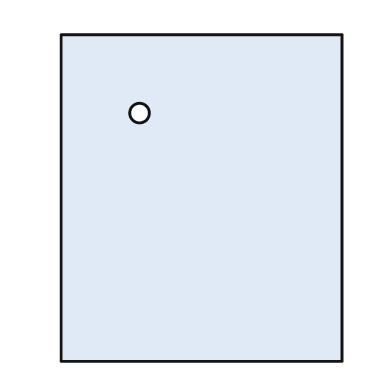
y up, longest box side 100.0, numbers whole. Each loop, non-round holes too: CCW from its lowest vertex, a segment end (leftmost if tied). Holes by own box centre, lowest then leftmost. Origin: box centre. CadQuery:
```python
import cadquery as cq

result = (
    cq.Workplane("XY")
    .moveTo(-43.0, -50.0)
    .lineTo(43.0, -50.0)
    .lineTo(43.0, 50.0)
    .lineTo(-43.0, 50.0)
    .close()
    .moveTo(-19.0, 26.0)
    .circle(3.0)
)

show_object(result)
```